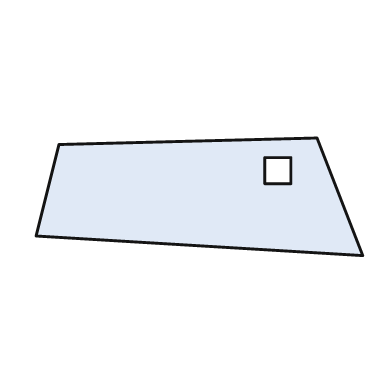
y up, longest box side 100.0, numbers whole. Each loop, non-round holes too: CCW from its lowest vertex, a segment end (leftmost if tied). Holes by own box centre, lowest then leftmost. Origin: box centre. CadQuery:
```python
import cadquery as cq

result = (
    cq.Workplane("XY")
    .moveTo(50.0, -18.0)
    .lineTo(36.0, 18.0)
    .lineTo(-43.0, 16.0)
    .lineTo(-50.0, -12.0)
    .close()
    .moveTo(20.0, 4.0)
    .lineTo(28.0, 4.0)
    .lineTo(28.0, 12.0)
    .lineTo(20.0, 12.0)
    .close()
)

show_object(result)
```